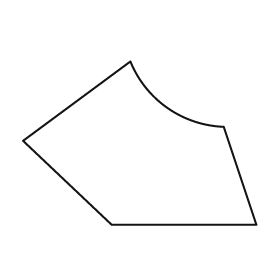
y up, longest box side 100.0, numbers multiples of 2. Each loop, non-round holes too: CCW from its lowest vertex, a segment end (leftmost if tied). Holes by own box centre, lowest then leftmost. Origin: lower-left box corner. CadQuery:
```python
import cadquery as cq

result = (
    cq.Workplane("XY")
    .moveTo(38.0, 0.0)
    .lineTo(100.0, 0.0)
    .lineTo(86.0, 42.0)
    .threePointArc((62.0, 50.0), (46.0, 70.0))
    .lineTo(0.0, 36.0)
    .close()
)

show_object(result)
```